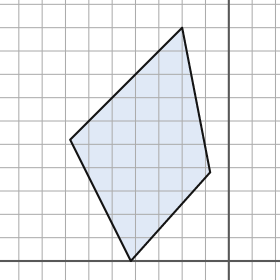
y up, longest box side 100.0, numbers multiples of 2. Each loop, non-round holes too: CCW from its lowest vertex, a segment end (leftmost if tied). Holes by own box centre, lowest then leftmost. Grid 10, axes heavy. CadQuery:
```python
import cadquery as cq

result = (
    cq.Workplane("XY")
    .moveTo(-42.0, 0.0)
    .lineTo(-8.0, 38.0)
    .lineTo(-20.0, 100.0)
    .lineTo(-68.0, 52.0)
    .close()
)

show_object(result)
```